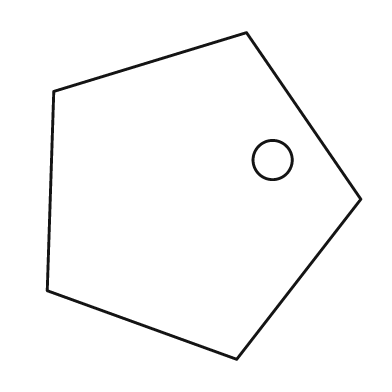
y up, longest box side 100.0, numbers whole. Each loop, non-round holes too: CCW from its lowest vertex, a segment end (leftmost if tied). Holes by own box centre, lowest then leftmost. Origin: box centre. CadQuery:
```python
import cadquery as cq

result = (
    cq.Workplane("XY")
    .moveTo(10.0, -50.0)
    .lineTo(48.0, -1.0)
    .lineTo(13.0, 50.0)
    .lineTo(-46.0, 32.0)
    .lineTo(-48.0, -29.0)
    .close()
    .moveTo(21.0, 11.0)
    .circle(6.0)
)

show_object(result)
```